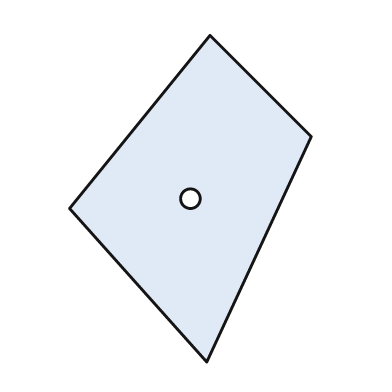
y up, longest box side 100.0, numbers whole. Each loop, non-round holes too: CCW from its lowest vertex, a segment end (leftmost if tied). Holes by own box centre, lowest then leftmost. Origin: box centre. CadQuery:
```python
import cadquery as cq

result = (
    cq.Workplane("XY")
    .moveTo(5.0, -50.0)
    .lineTo(37.0, 19.0)
    .lineTo(6.0, 50.0)
    .lineTo(-37.0, -3.0)
    .close()
    .moveTo(0.0, 0.0)
    .circle(3.0)
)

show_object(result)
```